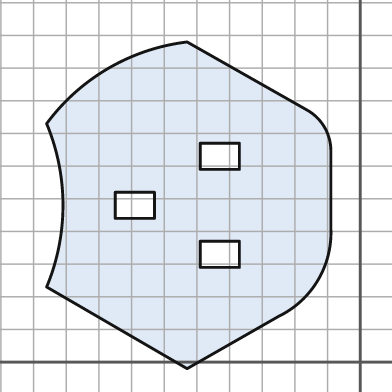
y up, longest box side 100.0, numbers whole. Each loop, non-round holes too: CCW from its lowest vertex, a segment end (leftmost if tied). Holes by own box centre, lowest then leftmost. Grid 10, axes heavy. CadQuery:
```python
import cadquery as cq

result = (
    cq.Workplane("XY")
    .moveTo(-53.0, -2.0)
    .lineTo(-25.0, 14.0)
    .threePointArc((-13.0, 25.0), (-9.0, 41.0))
    .lineTo(-9.0, 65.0)
    .threePointArc((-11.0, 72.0), (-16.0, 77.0))
    .lineTo(-53.0, 98.0)
    .threePointArc((-77.0, 90.0), (-96.0, 73.0))
    .threePointArc((-91.0, 48.0), (-96.0, 23.0))
    .close()
    .moveTo(-49.0, 29.0)
    .lineTo(-37.0, 29.0)
    .lineTo(-37.0, 37.0)
    .lineTo(-49.0, 37.0)
    .close()
    .moveTo(-75.0, 44.0)
    .lineTo(-63.0, 44.0)
    .lineTo(-63.0, 52.0)
    .lineTo(-75.0, 52.0)
    .close()
    .moveTo(-49.0, 59.0)
    .lineTo(-37.0, 59.0)
    .lineTo(-37.0, 67.0)
    .lineTo(-49.0, 67.0)
    .close()
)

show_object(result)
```